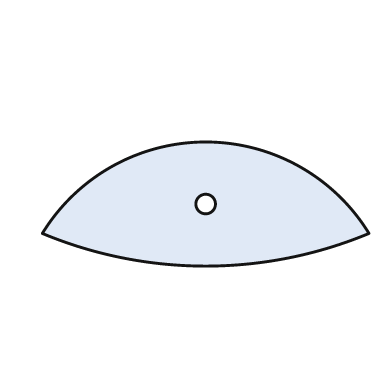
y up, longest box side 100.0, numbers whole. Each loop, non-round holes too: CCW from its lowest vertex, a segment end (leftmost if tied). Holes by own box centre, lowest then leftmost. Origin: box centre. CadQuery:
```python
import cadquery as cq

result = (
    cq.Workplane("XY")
    .moveTo(-50.0, -9.0)
    .threePointArc((0.0, -19.0), (50.0, -9.0))
    .threePointArc((0.0, 19.0), (-50.0, -9.0))
    .close()
    .moveTo(0.0, 0.0)
    .circle(3.0)
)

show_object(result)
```